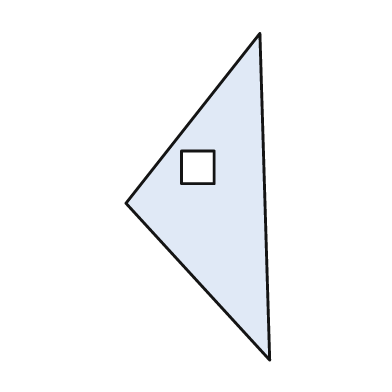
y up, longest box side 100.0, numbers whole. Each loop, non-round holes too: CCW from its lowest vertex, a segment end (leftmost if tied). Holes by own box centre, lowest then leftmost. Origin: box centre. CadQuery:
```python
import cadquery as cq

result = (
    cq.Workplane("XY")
    .moveTo(22.0, -50.0)
    .lineTo(19.0, 50.0)
    .lineTo(-22.0, -2.0)
    .close()
    .moveTo(-5.0, 4.0)
    .lineTo(5.0, 4.0)
    .lineTo(5.0, 14.0)
    .lineTo(-5.0, 14.0)
    .close()
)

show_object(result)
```